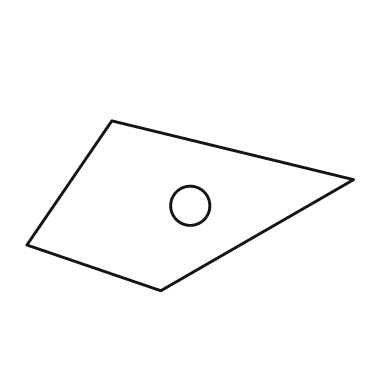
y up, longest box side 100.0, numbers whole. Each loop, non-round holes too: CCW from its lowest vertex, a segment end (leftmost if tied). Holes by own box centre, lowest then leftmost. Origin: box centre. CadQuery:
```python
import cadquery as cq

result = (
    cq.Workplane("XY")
    .moveTo(-9.0, -26.0)
    .lineTo(50.0, 8.0)
    .lineTo(-24.0, 26.0)
    .lineTo(-50.0, -12.0)
    .close()
    .moveTo(0.0, 0.0)
    .circle(6.0)
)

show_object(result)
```